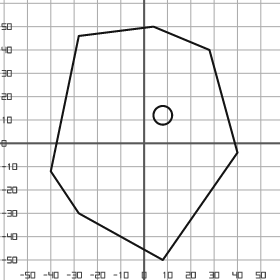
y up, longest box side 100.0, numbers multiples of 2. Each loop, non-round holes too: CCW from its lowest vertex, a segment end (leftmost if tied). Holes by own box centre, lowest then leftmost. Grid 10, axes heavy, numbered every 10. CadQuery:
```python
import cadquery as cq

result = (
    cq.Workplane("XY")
    .moveTo(8.0, -50.0)
    .lineTo(40.0, -4.0)
    .lineTo(28.0, 40.0)
    .lineTo(4.0, 50.0)
    .lineTo(-28.0, 46.0)
    .lineTo(-40.0, -12.0)
    .lineTo(-28.0, -30.0)
    .close()
    .moveTo(8.0, 12.0)
    .circle(4.0)
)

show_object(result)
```